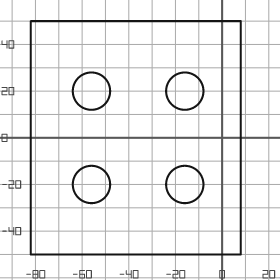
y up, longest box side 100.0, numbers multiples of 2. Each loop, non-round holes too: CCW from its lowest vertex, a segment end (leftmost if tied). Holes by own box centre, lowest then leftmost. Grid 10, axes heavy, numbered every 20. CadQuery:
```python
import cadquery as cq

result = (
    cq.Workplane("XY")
    .moveTo(-82.0, -50.0)
    .lineTo(8.0, -50.0)
    .lineTo(8.0, 50.0)
    .lineTo(-82.0, 50.0)
    .close()
    .moveTo(-56.0, -20.0)
    .circle(8.0)
    .moveTo(-16.0, -20.0)
    .circle(8.0)
    .moveTo(-56.0, 20.0)
    .circle(8.0)
    .moveTo(-16.0, 20.0)
    .circle(8.0)
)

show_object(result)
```